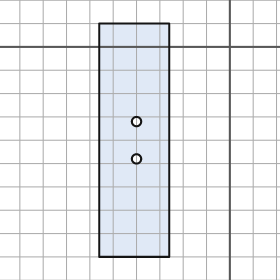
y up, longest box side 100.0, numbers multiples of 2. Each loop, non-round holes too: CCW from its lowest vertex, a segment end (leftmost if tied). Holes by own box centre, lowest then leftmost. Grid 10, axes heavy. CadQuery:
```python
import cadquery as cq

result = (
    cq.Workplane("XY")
    .moveTo(-56.0, -90.0)
    .lineTo(-26.0, -90.0)
    .lineTo(-26.0, 10.0)
    .lineTo(-56.0, 10.0)
    .close()
    .moveTo(-40.0, -48.0)
    .circle(2.0)
    .moveTo(-40.0, -32.0)
    .circle(2.0)
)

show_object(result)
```